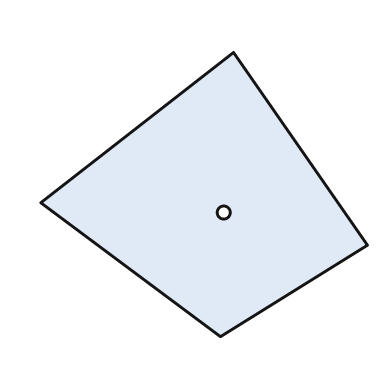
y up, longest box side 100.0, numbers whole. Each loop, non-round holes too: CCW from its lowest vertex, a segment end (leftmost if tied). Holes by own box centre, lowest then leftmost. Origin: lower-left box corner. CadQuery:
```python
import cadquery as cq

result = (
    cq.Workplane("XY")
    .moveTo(55.0, 0.0)
    .lineTo(100.0, 28.0)
    .lineTo(59.0, 87.0)
    .lineTo(0.0, 41.0)
    .close()
    .moveTo(56.0, 38.0)
    .circle(2.0)
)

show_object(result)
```